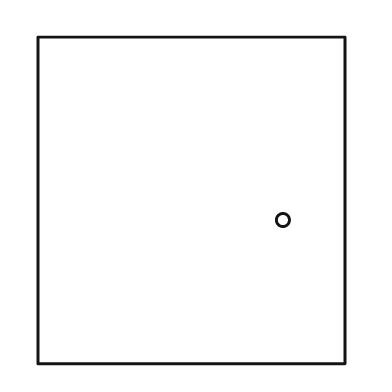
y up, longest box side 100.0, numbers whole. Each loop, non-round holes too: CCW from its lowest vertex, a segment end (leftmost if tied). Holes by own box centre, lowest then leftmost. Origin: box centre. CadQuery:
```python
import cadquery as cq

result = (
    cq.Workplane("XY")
    .moveTo(-47.0, -50.0)
    .lineTo(47.0, -50.0)
    .lineTo(47.0, 50.0)
    .lineTo(-47.0, 50.0)
    .close()
    .moveTo(28.0, -6.0)
    .circle(2.0)
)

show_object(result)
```